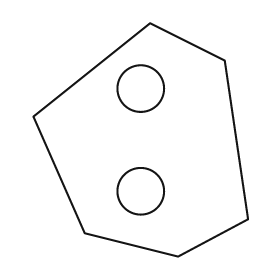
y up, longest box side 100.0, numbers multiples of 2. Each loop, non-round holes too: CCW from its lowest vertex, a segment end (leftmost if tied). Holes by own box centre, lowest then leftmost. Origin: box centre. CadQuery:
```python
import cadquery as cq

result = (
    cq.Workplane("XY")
    .moveTo(16.0, -50.0)
    .lineTo(46.0, -34.0)
    .lineTo(36.0, 34.0)
    .lineTo(4.0, 50.0)
    .lineTo(-46.0, 10.0)
    .lineTo(-24.0, -40.0)
    .close()
    .moveTo(0.0, -22.0)
    .circle(10.0)
    .moveTo(0.0, 22.0)
    .circle(10.0)
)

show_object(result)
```